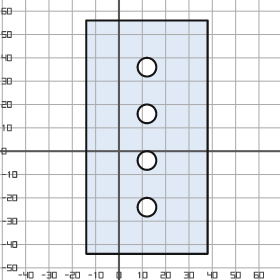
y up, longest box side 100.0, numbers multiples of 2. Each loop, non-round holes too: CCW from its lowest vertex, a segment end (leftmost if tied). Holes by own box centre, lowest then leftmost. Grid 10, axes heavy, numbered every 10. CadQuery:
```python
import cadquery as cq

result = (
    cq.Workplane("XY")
    .moveTo(-14.0, -44.0)
    .lineTo(38.0, -44.0)
    .lineTo(38.0, 56.0)
    .lineTo(-14.0, 56.0)
    .close()
    .moveTo(12.0, -24.0)
    .circle(4.0)
    .moveTo(12.0, -4.0)
    .circle(4.0)
    .moveTo(12.0, 16.0)
    .circle(4.0)
    .moveTo(12.0, 36.0)
    .circle(4.0)
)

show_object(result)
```